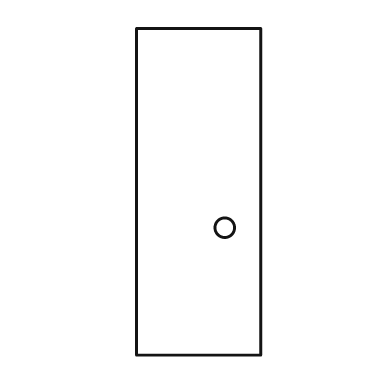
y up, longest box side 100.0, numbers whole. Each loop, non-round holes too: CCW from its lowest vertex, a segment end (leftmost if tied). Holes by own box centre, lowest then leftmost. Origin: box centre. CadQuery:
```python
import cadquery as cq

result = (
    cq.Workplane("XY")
    .moveTo(-19.0, -50.0)
    .lineTo(19.0, -50.0)
    .lineTo(19.0, 50.0)
    .lineTo(-19.0, 50.0)
    .close()
    .moveTo(8.0, -11.0)
    .circle(3.0)
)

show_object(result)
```